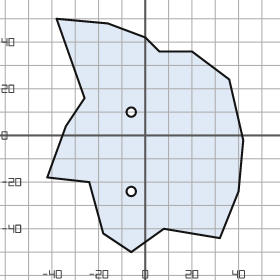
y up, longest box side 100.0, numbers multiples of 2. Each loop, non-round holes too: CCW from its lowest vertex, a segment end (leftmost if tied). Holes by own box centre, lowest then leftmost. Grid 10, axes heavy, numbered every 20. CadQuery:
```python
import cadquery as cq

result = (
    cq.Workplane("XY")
    .moveTo(-6.0, -50.0)
    .lineTo(8.0, -40.0)
    .lineTo(32.0, -44.0)
    .lineTo(40.0, -24.0)
    .lineTo(42.0, -2.0)
    .lineTo(36.0, 24.0)
    .lineTo(20.0, 36.0)
    .lineTo(6.0, 36.0)
    .lineTo(0.0, 42.0)
    .lineTo(-16.0, 48.0)
    .lineTo(-38.0, 50.0)
    .lineTo(-26.0, 16.0)
    .lineTo(-34.0, 4.0)
    .lineTo(-42.0, -18.0)
    .lineTo(-24.0, -20.0)
    .lineTo(-18.0, -42.0)
    .close()
    .moveTo(-6.0, -24.0)
    .circle(2.0)
    .moveTo(-6.0, 10.0)
    .circle(2.0)
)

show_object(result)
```